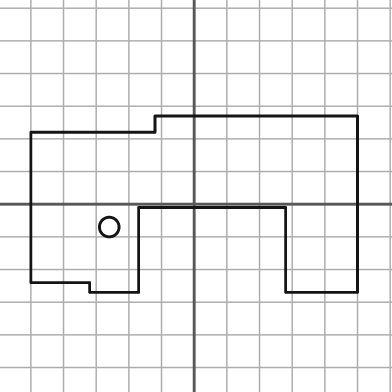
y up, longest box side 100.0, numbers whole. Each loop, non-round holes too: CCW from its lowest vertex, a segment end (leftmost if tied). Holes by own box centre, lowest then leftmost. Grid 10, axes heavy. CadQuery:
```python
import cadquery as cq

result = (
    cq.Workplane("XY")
    .moveTo(-32.0, -27.0)
    .lineTo(-17.0, -27.0)
    .lineTo(-17.0, -1.0)
    .lineTo(28.0, -1.0)
    .lineTo(28.0, -27.0)
    .lineTo(50.0, -27.0)
    .lineTo(50.0, 27.0)
    .lineTo(-12.0, 27.0)
    .lineTo(-12.0, 22.0)
    .lineTo(-50.0, 22.0)
    .lineTo(-50.0, -24.0)
    .lineTo(-32.0, -24.0)
    .close()
    .moveTo(-26.0, -7.0)
    .circle(3.0)
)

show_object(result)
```